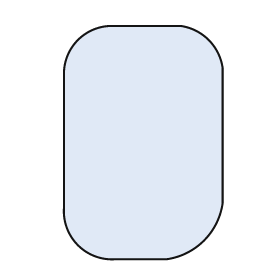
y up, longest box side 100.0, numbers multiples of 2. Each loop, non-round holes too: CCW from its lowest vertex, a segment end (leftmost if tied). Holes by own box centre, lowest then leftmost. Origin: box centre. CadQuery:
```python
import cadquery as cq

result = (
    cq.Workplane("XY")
    .moveTo(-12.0, -50.0)
    .lineTo(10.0, -50.0)
    .threePointArc((26.0, -42.0), (34.0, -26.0))
    .lineTo(34.0, 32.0)
    .threePointArc((28.0, 44.0), (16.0, 50.0))
    .lineTo(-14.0, 50.0)
    .threePointArc((-28.0, 44.0), (-34.0, 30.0))
    .lineTo(-34.0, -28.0)
    .threePointArc((-28.0, -44.0), (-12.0, -50.0))
    .close()
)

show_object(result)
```